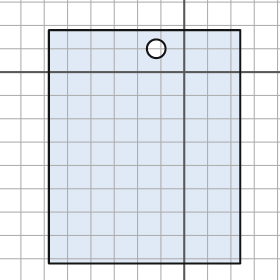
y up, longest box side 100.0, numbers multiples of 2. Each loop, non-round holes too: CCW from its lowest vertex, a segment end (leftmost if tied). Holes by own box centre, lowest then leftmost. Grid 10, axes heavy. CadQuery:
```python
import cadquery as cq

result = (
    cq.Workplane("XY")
    .moveTo(-58.0, -82.0)
    .lineTo(24.0, -82.0)
    .lineTo(24.0, 18.0)
    .lineTo(-58.0, 18.0)
    .close()
    .moveTo(-12.0, 10.0)
    .circle(4.0)
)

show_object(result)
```